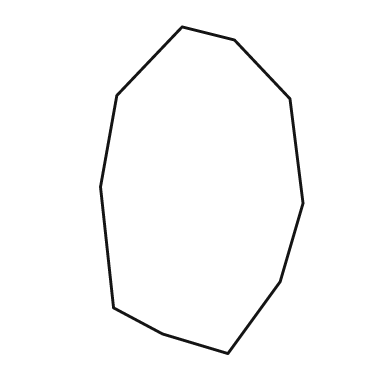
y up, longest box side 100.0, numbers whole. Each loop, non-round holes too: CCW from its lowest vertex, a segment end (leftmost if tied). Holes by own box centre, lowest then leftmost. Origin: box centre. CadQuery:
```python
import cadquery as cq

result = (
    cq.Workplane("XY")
    .moveTo(8.0, -50.0)
    .lineTo(24.0, -28.0)
    .lineTo(31.0, -4.0)
    .lineTo(27.0, 28.0)
    .lineTo(10.0, 46.0)
    .lineTo(-6.0, 50.0)
    .lineTo(-26.0, 29.0)
    .lineTo(-31.0, 1.0)
    .lineTo(-27.0, -36.0)
    .lineTo(-12.0, -44.0)
    .close()
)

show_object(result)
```